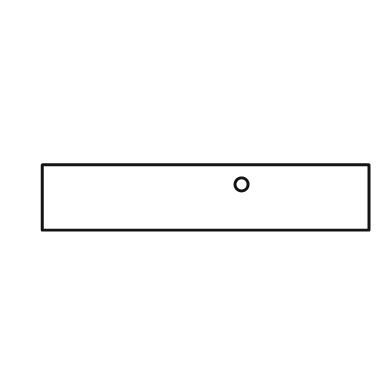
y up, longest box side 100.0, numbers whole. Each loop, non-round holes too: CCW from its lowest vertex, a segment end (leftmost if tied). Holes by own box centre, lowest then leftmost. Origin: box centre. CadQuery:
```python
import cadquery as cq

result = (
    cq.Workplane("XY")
    .moveTo(-50.0, -10.0)
    .lineTo(50.0, -10.0)
    .lineTo(50.0, 10.0)
    .lineTo(-50.0, 10.0)
    .close()
    .moveTo(11.0, 4.0)
    .circle(2.0)
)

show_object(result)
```